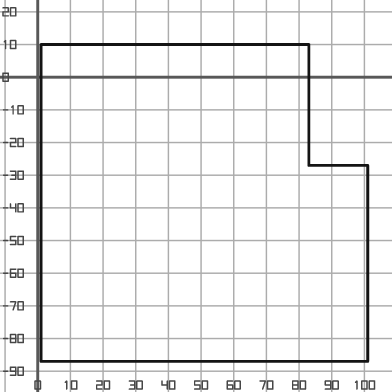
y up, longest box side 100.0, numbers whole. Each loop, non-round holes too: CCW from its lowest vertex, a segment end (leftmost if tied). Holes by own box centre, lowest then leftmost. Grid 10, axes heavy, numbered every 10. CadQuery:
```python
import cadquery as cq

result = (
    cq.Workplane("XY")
    .moveTo(1.0, -87.0)
    .lineTo(101.0, -87.0)
    .lineTo(101.0, -27.0)
    .lineTo(83.0, -27.0)
    .lineTo(83.0, 10.0)
    .lineTo(1.0, 10.0)
    .close()
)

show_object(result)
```